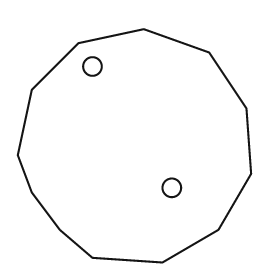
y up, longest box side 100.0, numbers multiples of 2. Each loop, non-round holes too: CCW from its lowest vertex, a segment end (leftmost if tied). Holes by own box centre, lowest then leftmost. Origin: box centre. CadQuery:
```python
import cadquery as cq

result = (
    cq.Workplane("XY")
    .moveTo(12.0, -50.0)
    .lineTo(36.0, -36.0)
    .lineTo(50.0, -12.0)
    .lineTo(48.0, 16.0)
    .lineTo(32.0, 40.0)
    .lineTo(4.0, 50.0)
    .lineTo(-24.0, 44.0)
    .lineTo(-44.0, 24.0)
    .lineTo(-50.0, -4.0)
    .lineTo(-44.0, -20.0)
    .lineTo(-32.0, -36.0)
    .lineTo(-18.0, -48.0)
    .close()
    .moveTo(16.0, -18.0)
    .circle(4.0)
    .moveTo(-18.0, 34.0)
    .circle(4.0)
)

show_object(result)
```